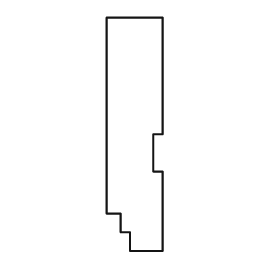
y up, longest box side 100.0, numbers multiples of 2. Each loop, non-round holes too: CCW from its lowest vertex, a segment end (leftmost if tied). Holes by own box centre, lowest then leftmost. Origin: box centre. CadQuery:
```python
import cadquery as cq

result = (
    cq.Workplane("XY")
    .moveTo(-2.0, -50.0)
    .lineTo(12.0, -50.0)
    .lineTo(12.0, -16.0)
    .lineTo(8.0, -16.0)
    .lineTo(8.0, 0.0)
    .lineTo(12.0, 0.0)
    .lineTo(12.0, 50.0)
    .lineTo(-12.0, 50.0)
    .lineTo(-12.0, -34.0)
    .lineTo(-6.0, -34.0)
    .lineTo(-6.0, -42.0)
    .lineTo(-2.0, -42.0)
    .close()
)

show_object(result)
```